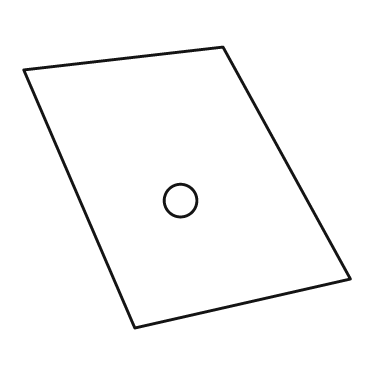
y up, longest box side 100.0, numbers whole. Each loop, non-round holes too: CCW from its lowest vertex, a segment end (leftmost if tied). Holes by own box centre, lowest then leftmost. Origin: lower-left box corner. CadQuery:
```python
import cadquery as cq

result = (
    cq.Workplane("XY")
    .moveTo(34.0, 0.0)
    .lineTo(100.0, 15.0)
    .lineTo(61.0, 86.0)
    .lineTo(0.0, 79.0)
    .close()
    .moveTo(48.0, 39.0)
    .circle(5.0)
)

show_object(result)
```